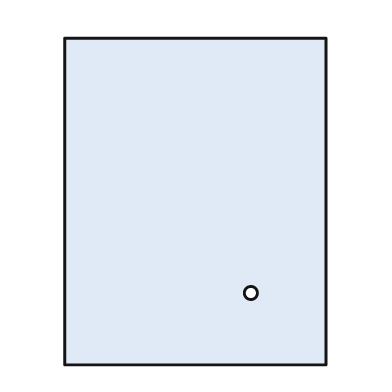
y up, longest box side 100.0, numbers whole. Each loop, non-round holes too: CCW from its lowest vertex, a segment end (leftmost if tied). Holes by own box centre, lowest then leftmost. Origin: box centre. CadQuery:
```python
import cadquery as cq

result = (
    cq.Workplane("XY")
    .moveTo(-40.0, -50.0)
    .lineTo(40.0, -50.0)
    .lineTo(40.0, 50.0)
    .lineTo(-40.0, 50.0)
    .close()
    .moveTo(17.0, -28.0)
    .circle(2.0)
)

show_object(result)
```